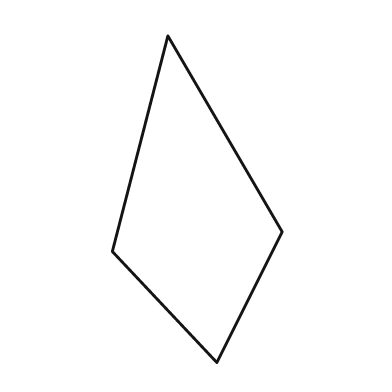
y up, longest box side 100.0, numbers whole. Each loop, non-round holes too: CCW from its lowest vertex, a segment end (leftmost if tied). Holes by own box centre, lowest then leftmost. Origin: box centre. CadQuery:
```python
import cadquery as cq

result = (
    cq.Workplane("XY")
    .moveTo(6.0, -50.0)
    .lineTo(26.0, -10.0)
    .lineTo(-9.0, 50.0)
    .lineTo(-26.0, -16.0)
    .close()
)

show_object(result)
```